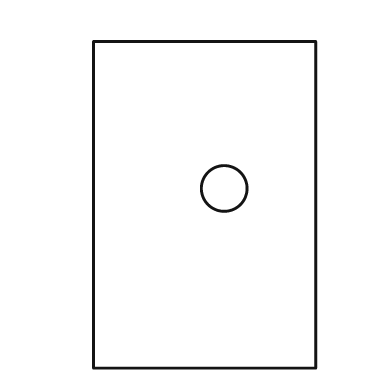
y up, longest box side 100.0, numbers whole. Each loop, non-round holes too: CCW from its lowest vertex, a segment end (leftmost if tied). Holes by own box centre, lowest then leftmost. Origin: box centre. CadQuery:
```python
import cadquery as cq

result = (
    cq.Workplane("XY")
    .moveTo(-34.0, -50.0)
    .lineTo(34.0, -50.0)
    .lineTo(34.0, 50.0)
    .lineTo(-34.0, 50.0)
    .close()
    .moveTo(6.0, 5.0)
    .circle(7.0)
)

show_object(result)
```